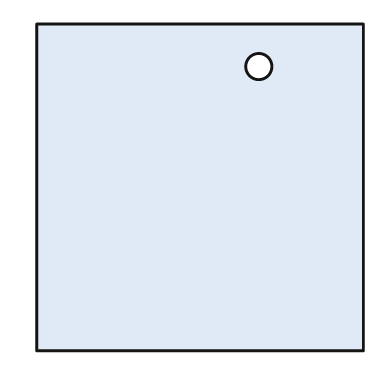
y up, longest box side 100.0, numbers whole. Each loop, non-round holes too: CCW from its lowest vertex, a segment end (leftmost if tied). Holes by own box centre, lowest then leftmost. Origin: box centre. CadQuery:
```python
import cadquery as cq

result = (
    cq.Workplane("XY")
    .moveTo(-50.0, -50.0)
    .lineTo(50.0, -50.0)
    .lineTo(50.0, 50.0)
    .lineTo(-50.0, 50.0)
    .close()
    .moveTo(18.0, 37.0)
    .circle(4.0)
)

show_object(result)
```